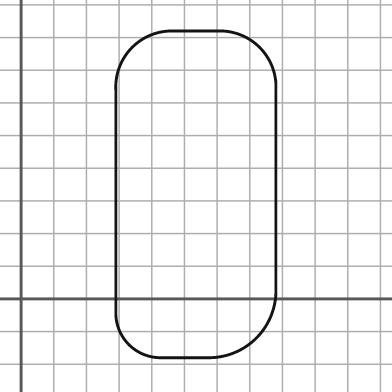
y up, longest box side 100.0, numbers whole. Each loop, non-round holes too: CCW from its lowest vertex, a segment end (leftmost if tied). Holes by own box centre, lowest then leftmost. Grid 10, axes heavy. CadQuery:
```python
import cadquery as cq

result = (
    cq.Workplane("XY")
    .moveTo(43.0, -18.0)
    .lineTo(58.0, -18.0)
    .threePointArc((72.0, -12.0), (78.0, 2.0))
    .lineTo(78.0, 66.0)
    .threePointArc((73.0, 77.0), (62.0, 82.0))
    .lineTo(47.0, 82.0)
    .threePointArc((34.0, 77.0), (29.0, 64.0))
    .lineTo(29.0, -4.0)
    .threePointArc((33.0, -14.0), (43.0, -18.0))
    .close()
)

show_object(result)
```